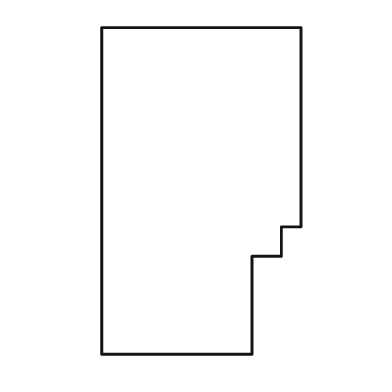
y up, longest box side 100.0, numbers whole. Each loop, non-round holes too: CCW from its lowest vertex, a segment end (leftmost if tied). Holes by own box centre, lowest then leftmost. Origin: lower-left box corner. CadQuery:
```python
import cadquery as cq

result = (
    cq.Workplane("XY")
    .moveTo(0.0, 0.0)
    .lineTo(46.0, 0.0)
    .lineTo(46.0, 30.0)
    .lineTo(55.0, 30.0)
    .lineTo(55.0, 39.0)
    .lineTo(61.0, 39.0)
    .lineTo(61.0, 100.0)
    .lineTo(0.0, 100.0)
    .close()
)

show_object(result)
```